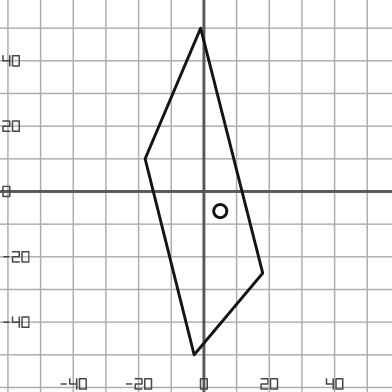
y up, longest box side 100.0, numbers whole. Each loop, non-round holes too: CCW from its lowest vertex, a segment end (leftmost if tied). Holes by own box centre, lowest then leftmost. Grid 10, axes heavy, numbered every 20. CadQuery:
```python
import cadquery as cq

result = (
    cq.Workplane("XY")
    .moveTo(-3.0, -50.0)
    .lineTo(18.0, -25.0)
    .lineTo(-1.0, 50.0)
    .lineTo(-18.0, 10.0)
    .close()
    .moveTo(5.0, -6.0)
    .circle(2.0)
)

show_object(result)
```